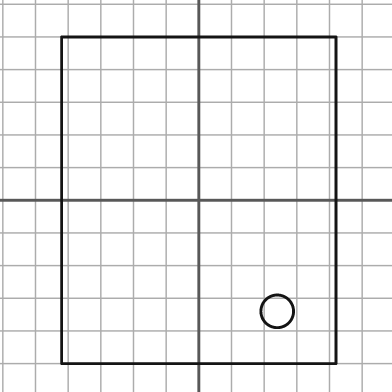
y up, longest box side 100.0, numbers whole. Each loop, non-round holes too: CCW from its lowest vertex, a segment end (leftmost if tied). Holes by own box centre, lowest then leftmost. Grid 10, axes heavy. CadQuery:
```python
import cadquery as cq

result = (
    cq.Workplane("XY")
    .moveTo(-42.0, -50.0)
    .lineTo(42.0, -50.0)
    .lineTo(42.0, 50.0)
    .lineTo(-42.0, 50.0)
    .close()
    .moveTo(24.0, -34.0)
    .circle(5.0)
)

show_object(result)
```